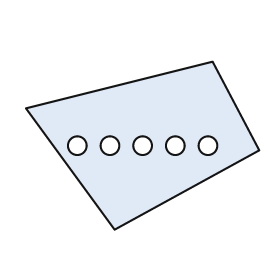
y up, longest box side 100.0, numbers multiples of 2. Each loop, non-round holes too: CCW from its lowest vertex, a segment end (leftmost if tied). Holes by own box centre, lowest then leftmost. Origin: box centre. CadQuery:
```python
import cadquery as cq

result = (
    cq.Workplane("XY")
    .moveTo(-12.0, -36.0)
    .lineTo(50.0, -2.0)
    .lineTo(30.0, 36.0)
    .lineTo(-50.0, 16.0)
    .close()
    .moveTo(-28.0, 0.0)
    .circle(4.0)
    .moveTo(-14.0, 0.0)
    .circle(4.0)
    .moveTo(0.0, 0.0)
    .circle(4.0)
    .moveTo(14.0, 0.0)
    .circle(4.0)
    .moveTo(28.0, 0.0)
    .circle(4.0)
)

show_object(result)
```